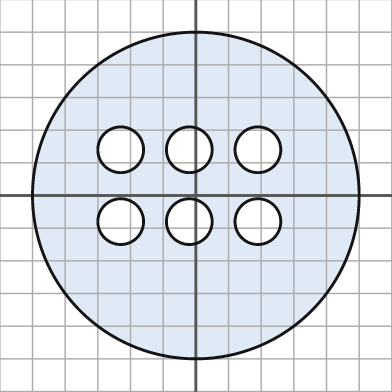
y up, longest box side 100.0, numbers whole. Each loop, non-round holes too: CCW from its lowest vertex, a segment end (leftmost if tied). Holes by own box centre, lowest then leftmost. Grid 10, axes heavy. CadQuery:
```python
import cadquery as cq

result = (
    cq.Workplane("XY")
    .moveTo(0.0, 0.0)
    .circle(50.0)
    .moveTo(-23.0, -8.0)
    .circle(7.0)
    .moveTo(-2.0, -8.0)
    .circle(7.0)
    .moveTo(19.0, -8.0)
    .circle(7.0)
    .moveTo(-23.0, 14.0)
    .circle(7.0)
    .moveTo(-2.0, 14.0)
    .circle(7.0)
    .moveTo(19.0, 14.0)
    .circle(7.0)
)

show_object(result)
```